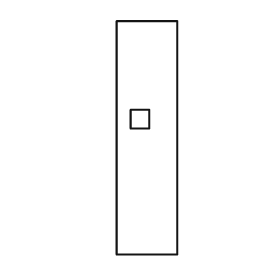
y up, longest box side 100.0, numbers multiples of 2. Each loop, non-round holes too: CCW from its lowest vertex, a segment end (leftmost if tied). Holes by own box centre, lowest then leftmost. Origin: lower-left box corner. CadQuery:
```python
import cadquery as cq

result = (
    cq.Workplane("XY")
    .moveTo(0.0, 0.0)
    .lineTo(26.0, 0.0)
    .lineTo(26.0, 100.0)
    .lineTo(0.0, 100.0)
    .close()
    .moveTo(6.0, 54.0)
    .lineTo(14.0, 54.0)
    .lineTo(14.0, 62.0)
    .lineTo(6.0, 62.0)
    .close()
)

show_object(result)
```